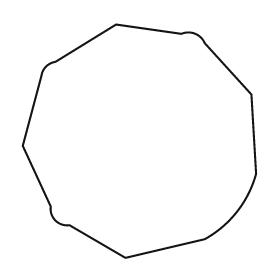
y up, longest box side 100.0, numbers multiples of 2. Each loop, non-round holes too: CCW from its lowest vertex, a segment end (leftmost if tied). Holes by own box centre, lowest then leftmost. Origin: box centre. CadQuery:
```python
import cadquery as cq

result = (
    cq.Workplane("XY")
    .moveTo(-6.0, -50.0)
    .lineTo(28.0, -42.0)
    .threePointArc((42.0, -30.0), (50.0, -14.0))
    .lineTo(48.0, 20.0)
    .lineTo(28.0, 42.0)
    .threePointArc((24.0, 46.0), (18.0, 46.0))
    .lineTo(-10.0, 50.0)
    .lineTo(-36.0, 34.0)
    .threePointArc((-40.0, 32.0), (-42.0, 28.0))
    .lineTo(-50.0, -2.0)
    .lineTo(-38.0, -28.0)
    .threePointArc((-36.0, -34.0), (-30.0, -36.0))
    .close()
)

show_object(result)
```